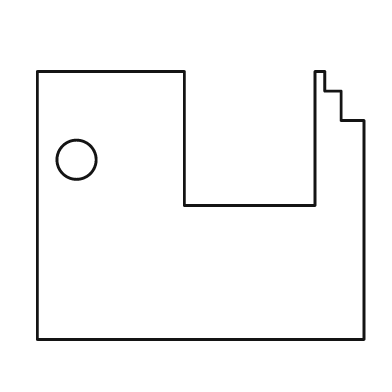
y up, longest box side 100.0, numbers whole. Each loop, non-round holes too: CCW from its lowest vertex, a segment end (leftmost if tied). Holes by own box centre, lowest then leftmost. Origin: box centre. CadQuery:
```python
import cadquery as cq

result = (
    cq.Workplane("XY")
    .moveTo(-50.0, -41.0)
    .lineTo(50.0, -41.0)
    .lineTo(50.0, 26.0)
    .lineTo(43.0, 26.0)
    .lineTo(43.0, 35.0)
    .lineTo(38.0, 35.0)
    .lineTo(38.0, 41.0)
    .lineTo(35.0, 41.0)
    .lineTo(35.0, 0.0)
    .lineTo(-5.0, 0.0)
    .lineTo(-5.0, 41.0)
    .lineTo(-50.0, 41.0)
    .close()
    .moveTo(-38.0, 14.0)
    .circle(6.0)
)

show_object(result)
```